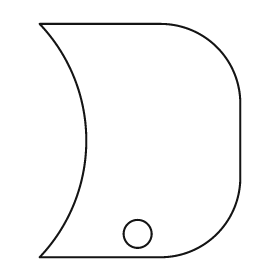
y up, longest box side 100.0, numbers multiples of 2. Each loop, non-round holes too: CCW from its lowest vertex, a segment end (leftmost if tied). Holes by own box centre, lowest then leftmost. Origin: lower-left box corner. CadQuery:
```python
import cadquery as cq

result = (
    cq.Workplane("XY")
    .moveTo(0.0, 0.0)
    .lineTo(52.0, 0.0)
    .threePointArc((76.0, 10.0), (86.0, 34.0))
    .lineTo(86.0, 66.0)
    .threePointArc((76.0, 90.0), (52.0, 100.0))
    .lineTo(0.0, 100.0)
    .threePointArc((20.0, 50.0), (0.0, 0.0))
    .close()
    .moveTo(42.0, 10.0)
    .circle(6.0)
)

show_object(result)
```